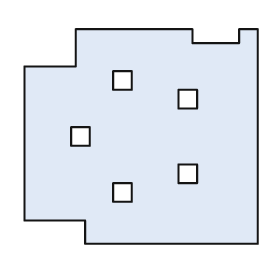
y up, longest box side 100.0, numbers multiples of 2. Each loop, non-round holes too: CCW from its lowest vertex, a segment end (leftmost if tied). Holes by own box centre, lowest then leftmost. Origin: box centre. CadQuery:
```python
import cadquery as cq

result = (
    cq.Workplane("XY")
    .moveTo(-24.0, -46.0)
    .lineTo(50.0, -46.0)
    .lineTo(50.0, 46.0)
    .lineTo(42.0, 46.0)
    .lineTo(42.0, 40.0)
    .lineTo(22.0, 40.0)
    .lineTo(22.0, 46.0)
    .lineTo(-28.0, 46.0)
    .lineTo(-28.0, 30.0)
    .lineTo(-50.0, 30.0)
    .lineTo(-50.0, -36.0)
    .lineTo(-24.0, -36.0)
    .close()
    .moveTo(-12.0, -28.0)
    .lineTo(-4.0, -28.0)
    .lineTo(-4.0, -20.0)
    .lineTo(-12.0, -20.0)
    .close()
    .moveTo(16.0, -20.0)
    .lineTo(24.0, -20.0)
    .lineTo(24.0, -12.0)
    .lineTo(16.0, -12.0)
    .close()
    .moveTo(-30.0, -4.0)
    .lineTo(-22.0, -4.0)
    .lineTo(-22.0, 4.0)
    .lineTo(-30.0, 4.0)
    .close()
    .moveTo(16.0, 12.0)
    .lineTo(24.0, 12.0)
    .lineTo(24.0, 20.0)
    .lineTo(16.0, 20.0)
    .close()
    .moveTo(-12.0, 20.0)
    .lineTo(-4.0, 20.0)
    .lineTo(-4.0, 28.0)
    .lineTo(-12.0, 28.0)
    .close()
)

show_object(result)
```